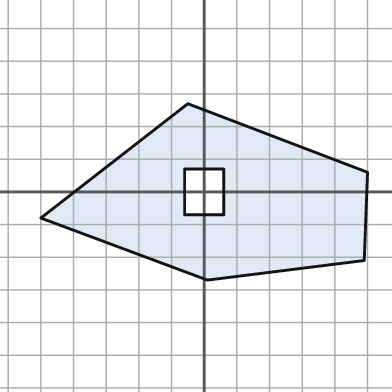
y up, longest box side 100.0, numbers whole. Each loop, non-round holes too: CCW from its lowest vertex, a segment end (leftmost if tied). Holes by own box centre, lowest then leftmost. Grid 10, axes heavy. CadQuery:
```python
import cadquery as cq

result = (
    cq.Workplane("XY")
    .moveTo(1.0, -27.0)
    .lineTo(49.0, -21.0)
    .lineTo(50.0, 6.0)
    .lineTo(-5.0, 27.0)
    .lineTo(-50.0, -8.0)
    .close()
    .moveTo(-6.0, -7.0)
    .lineTo(6.0, -7.0)
    .lineTo(6.0, 7.0)
    .lineTo(-6.0, 7.0)
    .close()
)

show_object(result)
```